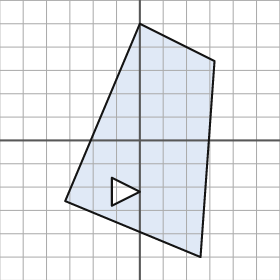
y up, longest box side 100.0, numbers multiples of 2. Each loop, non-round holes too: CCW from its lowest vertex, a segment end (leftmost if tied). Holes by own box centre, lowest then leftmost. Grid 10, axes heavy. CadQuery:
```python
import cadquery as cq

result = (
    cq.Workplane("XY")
    .moveTo(26.0, -50.0)
    .lineTo(32.0, 34.0)
    .lineTo(0.0, 50.0)
    .lineTo(-32.0, -26.0)
    .close()
    .moveTo(-12.0, -28.0)
    .lineTo(0.0, -22.0)
    .lineTo(-12.0, -16.0)
    .close()
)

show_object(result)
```